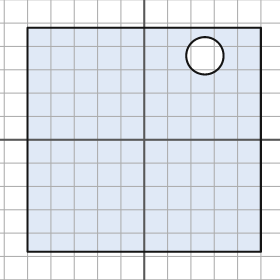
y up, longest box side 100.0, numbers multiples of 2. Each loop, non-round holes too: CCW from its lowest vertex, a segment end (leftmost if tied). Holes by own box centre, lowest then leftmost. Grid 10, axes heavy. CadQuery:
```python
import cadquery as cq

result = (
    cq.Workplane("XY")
    .moveTo(-50.0, -48.0)
    .lineTo(50.0, -48.0)
    .lineTo(50.0, 48.0)
    .lineTo(-50.0, 48.0)
    .close()
    .moveTo(26.0, 36.0)
    .circle(8.0)
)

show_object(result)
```